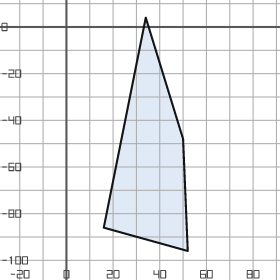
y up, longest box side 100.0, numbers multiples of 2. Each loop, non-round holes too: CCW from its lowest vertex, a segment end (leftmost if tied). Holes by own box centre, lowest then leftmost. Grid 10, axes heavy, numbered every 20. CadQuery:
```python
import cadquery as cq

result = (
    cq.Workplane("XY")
    .moveTo(52.0, -96.0)
    .lineTo(50.0, -48.0)
    .lineTo(34.0, 4.0)
    .lineTo(16.0, -86.0)
    .close()
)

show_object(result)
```